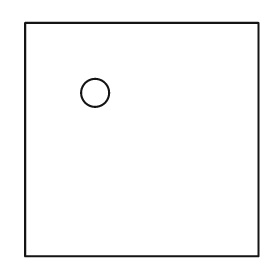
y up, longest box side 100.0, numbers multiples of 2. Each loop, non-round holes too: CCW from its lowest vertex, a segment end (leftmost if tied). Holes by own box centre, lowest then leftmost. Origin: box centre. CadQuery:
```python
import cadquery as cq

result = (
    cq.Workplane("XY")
    .moveTo(-50.0, -50.0)
    .lineTo(50.0, -50.0)
    .lineTo(50.0, 50.0)
    .lineTo(-50.0, 50.0)
    .close()
    .moveTo(-20.0, 20.0)
    .circle(6.0)
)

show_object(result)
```